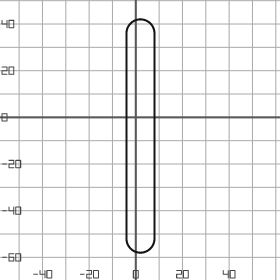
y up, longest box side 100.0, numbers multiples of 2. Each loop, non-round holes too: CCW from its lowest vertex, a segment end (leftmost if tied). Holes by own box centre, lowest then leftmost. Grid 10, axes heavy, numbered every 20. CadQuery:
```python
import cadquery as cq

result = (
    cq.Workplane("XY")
    .moveTo(-4.0, -52.0)
    .threePointArc((2.0, -58.0), (8.0, -52.0))
    .lineTo(8.0, 36.0)
    .threePointArc((2.0, 42.0), (-4.0, 36.0))
    .close()
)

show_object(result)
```